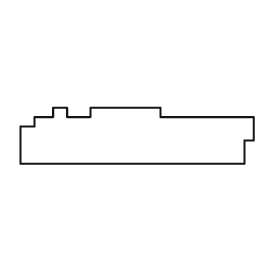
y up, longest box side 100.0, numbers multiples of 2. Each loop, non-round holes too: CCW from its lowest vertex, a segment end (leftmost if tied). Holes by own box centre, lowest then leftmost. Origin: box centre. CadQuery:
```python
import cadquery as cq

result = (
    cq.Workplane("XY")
    .moveTo(-50.0, -12.0)
    .lineTo(46.0, -12.0)
    .lineTo(46.0, -2.0)
    .lineTo(50.0, -2.0)
    .lineTo(50.0, 8.0)
    .lineTo(10.0, 8.0)
    .lineTo(10.0, 12.0)
    .lineTo(-20.0, 12.0)
    .lineTo(-20.0, 8.0)
    .lineTo(-30.0, 8.0)
    .lineTo(-30.0, 12.0)
    .lineTo(-36.0, 12.0)
    .lineTo(-36.0, 8.0)
    .lineTo(-44.0, 8.0)
    .lineTo(-44.0, 4.0)
    .lineTo(-50.0, 4.0)
    .close()
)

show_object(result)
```